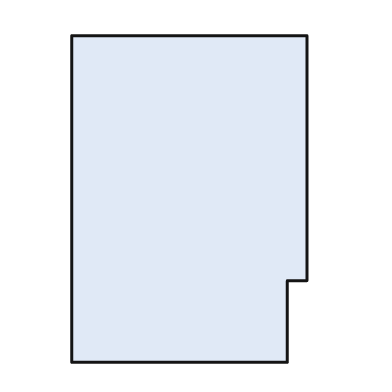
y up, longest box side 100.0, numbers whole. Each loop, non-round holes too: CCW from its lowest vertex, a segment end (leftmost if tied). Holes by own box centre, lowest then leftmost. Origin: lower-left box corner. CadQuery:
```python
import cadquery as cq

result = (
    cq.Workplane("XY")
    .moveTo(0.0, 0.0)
    .lineTo(66.0, 0.0)
    .lineTo(66.0, 25.0)
    .lineTo(72.0, 25.0)
    .lineTo(72.0, 100.0)
    .lineTo(0.0, 100.0)
    .close()
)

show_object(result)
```